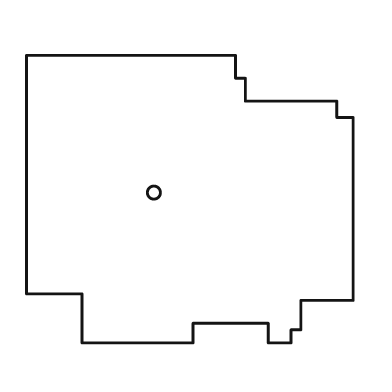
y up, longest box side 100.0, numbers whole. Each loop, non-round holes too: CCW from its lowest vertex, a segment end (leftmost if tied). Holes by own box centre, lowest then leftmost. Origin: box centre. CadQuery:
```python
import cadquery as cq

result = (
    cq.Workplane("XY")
    .moveTo(-33.0, -44.0)
    .lineTo(1.0, -44.0)
    .lineTo(1.0, -38.0)
    .lineTo(24.0, -38.0)
    .lineTo(24.0, -44.0)
    .lineTo(31.0, -44.0)
    .lineTo(31.0, -40.0)
    .lineTo(34.0, -40.0)
    .lineTo(34.0, -31.0)
    .lineTo(50.0, -31.0)
    .lineTo(50.0, 25.0)
    .lineTo(45.0, 25.0)
    .lineTo(45.0, 30.0)
    .lineTo(17.0, 30.0)
    .lineTo(17.0, 37.0)
    .lineTo(14.0, 37.0)
    .lineTo(14.0, 44.0)
    .lineTo(-50.0, 44.0)
    .lineTo(-50.0, -29.0)
    .lineTo(-33.0, -29.0)
    .close()
    .moveTo(-11.0, 2.0)
    .circle(2.0)
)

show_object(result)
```